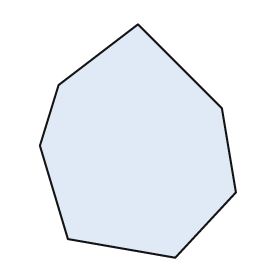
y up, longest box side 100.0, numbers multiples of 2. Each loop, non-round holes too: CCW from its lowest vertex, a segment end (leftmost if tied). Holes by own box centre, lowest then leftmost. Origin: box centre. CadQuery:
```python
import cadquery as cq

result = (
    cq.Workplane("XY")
    .moveTo(16.0, -50.0)
    .lineTo(42.0, -22.0)
    .lineTo(36.0, 14.0)
    .lineTo(0.0, 50.0)
    .lineTo(-34.0, 24.0)
    .lineTo(-42.0, -2.0)
    .lineTo(-30.0, -42.0)
    .close()
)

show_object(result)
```